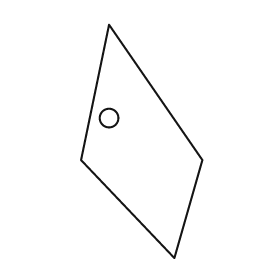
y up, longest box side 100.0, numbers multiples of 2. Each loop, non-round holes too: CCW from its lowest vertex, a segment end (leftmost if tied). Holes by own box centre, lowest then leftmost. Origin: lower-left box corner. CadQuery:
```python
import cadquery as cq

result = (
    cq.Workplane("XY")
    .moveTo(40.0, 0.0)
    .lineTo(52.0, 42.0)
    .lineTo(12.0, 100.0)
    .lineTo(0.0, 42.0)
    .close()
    .moveTo(12.0, 60.0)
    .circle(4.0)
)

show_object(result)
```